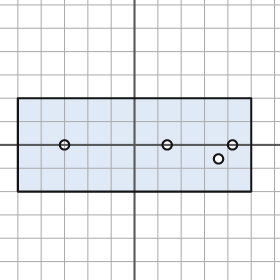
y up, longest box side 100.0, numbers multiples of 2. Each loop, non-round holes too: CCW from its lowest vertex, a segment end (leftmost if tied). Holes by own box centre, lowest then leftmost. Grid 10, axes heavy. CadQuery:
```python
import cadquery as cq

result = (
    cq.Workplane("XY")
    .moveTo(-50.0, -20.0)
    .lineTo(50.0, -20.0)
    .lineTo(50.0, 20.0)
    .lineTo(-50.0, 20.0)
    .close()
    .moveTo(36.0, -6.0)
    .circle(2.0)
    .moveTo(-30.0, 0.0)
    .circle(2.0)
    .moveTo(14.0, 0.0)
    .circle(2.0)
    .moveTo(42.0, 0.0)
    .circle(2.0)
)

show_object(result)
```